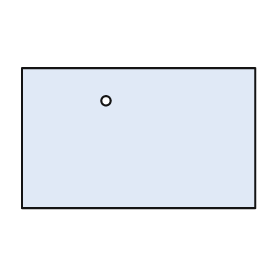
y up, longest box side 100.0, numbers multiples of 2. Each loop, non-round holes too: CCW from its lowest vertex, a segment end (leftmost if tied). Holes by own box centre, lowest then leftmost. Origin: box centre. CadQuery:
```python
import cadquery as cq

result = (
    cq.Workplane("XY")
    .moveTo(-50.0, -30.0)
    .lineTo(50.0, -30.0)
    .lineTo(50.0, 30.0)
    .lineTo(-50.0, 30.0)
    .close()
    .moveTo(-14.0, 16.0)
    .circle(2.0)
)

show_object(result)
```